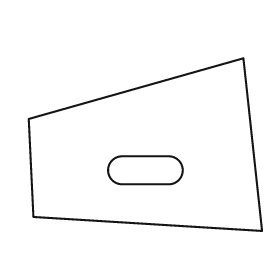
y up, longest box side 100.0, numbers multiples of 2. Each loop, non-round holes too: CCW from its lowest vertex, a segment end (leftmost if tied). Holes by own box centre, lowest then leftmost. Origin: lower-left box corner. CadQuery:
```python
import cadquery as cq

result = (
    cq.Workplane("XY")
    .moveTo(100.0, 0.0)
    .lineTo(92.0, 74.0)
    .lineTo(0.0, 48.0)
    .lineTo(2.0, 6.0)
    .close()
    .moveTo(40.0, 20.0)
    .lineTo(60.0, 20.0)
    .threePointArc((66.0, 26.0), (60.0, 32.0))
    .lineTo(40.0, 32.0)
    .threePointArc((34.0, 26.0), (40.0, 20.0))
    .close()
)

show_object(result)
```